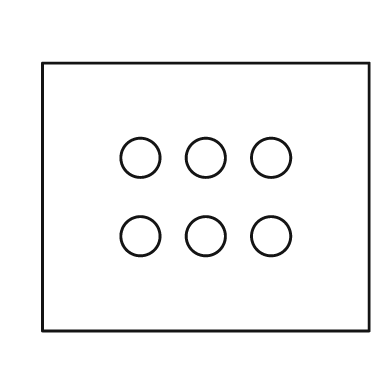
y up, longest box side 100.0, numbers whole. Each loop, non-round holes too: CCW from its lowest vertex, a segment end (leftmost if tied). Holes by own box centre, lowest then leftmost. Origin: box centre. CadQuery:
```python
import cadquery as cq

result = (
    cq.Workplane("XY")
    .moveTo(-50.0, -41.0)
    .lineTo(50.0, -41.0)
    .lineTo(50.0, 41.0)
    .lineTo(-50.0, 41.0)
    .close()
    .moveTo(-20.0, -12.0)
    .circle(6.0)
    .moveTo(0.0, -12.0)
    .circle(6.0)
    .moveTo(20.0, -12.0)
    .circle(6.0)
    .moveTo(-20.0, 12.0)
    .circle(6.0)
    .moveTo(0.0, 12.0)
    .circle(6.0)
    .moveTo(20.0, 12.0)
    .circle(6.0)
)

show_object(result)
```